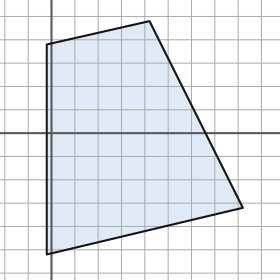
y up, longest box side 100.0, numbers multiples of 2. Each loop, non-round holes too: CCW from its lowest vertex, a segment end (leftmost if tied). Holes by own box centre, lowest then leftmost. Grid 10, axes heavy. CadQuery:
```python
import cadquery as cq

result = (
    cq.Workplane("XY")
    .moveTo(-2.0, -52.0)
    .lineTo(82.0, -32.0)
    .lineTo(42.0, 48.0)
    .lineTo(-2.0, 38.0)
    .close()
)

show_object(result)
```